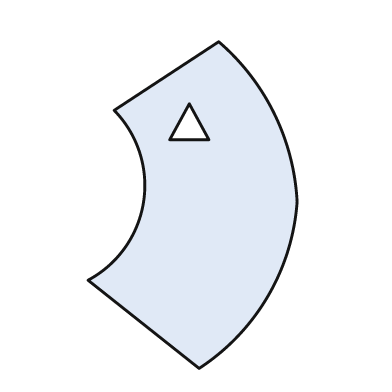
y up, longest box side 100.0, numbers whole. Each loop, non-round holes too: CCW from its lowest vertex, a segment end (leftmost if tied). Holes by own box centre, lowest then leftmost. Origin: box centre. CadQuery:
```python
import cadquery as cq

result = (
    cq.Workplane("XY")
    .moveTo(2.0, -50.0)
    .threePointArc((23.0, -28.0), (32.0, 1.0))
    .threePointArc((25.0, 28.0), (8.0, 50.0))
    .lineTo(-24.0, 29.0)
    .threePointArc((-15.0, 1.0), (-32.0, -23.0))
    .close()
    .moveTo(-7.0, 20.0)
    .lineTo(5.0, 20.0)
    .lineTo(-1.0, 31.0)
    .close()
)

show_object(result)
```